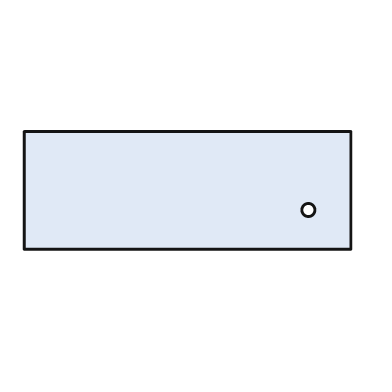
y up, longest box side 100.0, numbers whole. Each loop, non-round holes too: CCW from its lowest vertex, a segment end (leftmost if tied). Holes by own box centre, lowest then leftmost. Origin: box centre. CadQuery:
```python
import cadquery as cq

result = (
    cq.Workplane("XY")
    .moveTo(-50.0, -18.0)
    .lineTo(50.0, -18.0)
    .lineTo(50.0, 18.0)
    .lineTo(-50.0, 18.0)
    .close()
    .moveTo(37.0, -6.0)
    .circle(2.0)
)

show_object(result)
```